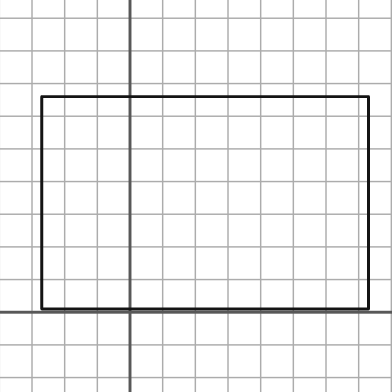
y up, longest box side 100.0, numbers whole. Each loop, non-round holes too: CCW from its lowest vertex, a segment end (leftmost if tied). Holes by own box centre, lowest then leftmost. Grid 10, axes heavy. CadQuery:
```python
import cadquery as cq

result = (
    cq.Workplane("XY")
    .moveTo(-27.0, 1.0)
    .lineTo(73.0, 1.0)
    .lineTo(73.0, 66.0)
    .lineTo(-27.0, 66.0)
    .close()
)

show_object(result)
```